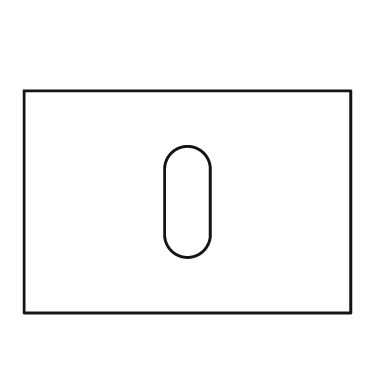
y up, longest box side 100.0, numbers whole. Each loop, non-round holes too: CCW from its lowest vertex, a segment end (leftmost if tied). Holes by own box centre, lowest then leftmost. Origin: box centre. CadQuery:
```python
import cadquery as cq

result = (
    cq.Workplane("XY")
    .moveTo(-50.0, -34.0)
    .lineTo(50.0, -34.0)
    .lineTo(50.0, 34.0)
    .lineTo(-50.0, 34.0)
    .close()
    .moveTo(-7.0, -10.0)
    .threePointArc((0.0, -17.0), (7.0, -10.0))
    .lineTo(7.0, 10.0)
    .threePointArc((0.0, 17.0), (-7.0, 10.0))
    .close()
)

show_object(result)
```